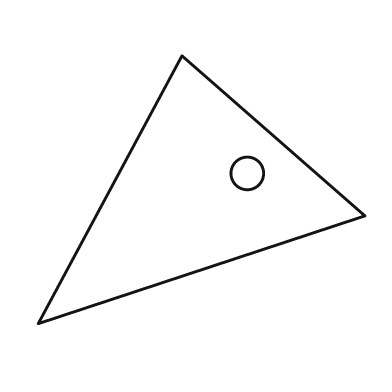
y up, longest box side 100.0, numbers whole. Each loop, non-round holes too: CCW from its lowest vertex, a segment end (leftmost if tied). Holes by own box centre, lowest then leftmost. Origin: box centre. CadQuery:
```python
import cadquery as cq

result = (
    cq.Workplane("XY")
    .moveTo(-50.0, -41.0)
    .lineTo(50.0, -8.0)
    .lineTo(-6.0, 41.0)
    .close()
    .moveTo(14.0, 5.0)
    .circle(5.0)
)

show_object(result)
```